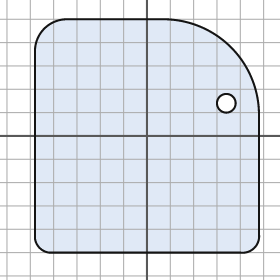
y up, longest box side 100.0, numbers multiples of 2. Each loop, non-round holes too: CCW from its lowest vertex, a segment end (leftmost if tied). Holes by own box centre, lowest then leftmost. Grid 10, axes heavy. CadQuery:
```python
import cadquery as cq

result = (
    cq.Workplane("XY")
    .moveTo(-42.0, -50.0)
    .lineTo(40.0, -50.0)
    .threePointArc((46.0, -48.0), (48.0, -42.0))
    .lineTo(48.0, 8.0)
    .threePointArc((36.0, 38.0), (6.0, 50.0))
    .lineTo(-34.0, 50.0)
    .threePointArc((-44.0, 46.0), (-48.0, 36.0))
    .lineTo(-48.0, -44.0)
    .threePointArc((-46.0, -48.0), (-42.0, -50.0))
    .close()
    .moveTo(34.0, 14.0)
    .circle(4.0)
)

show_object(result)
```